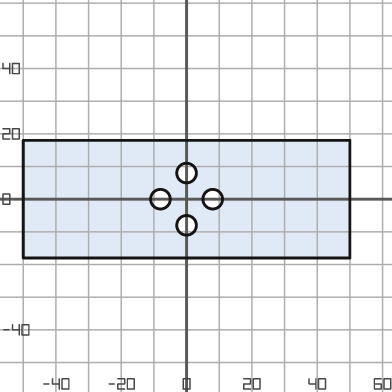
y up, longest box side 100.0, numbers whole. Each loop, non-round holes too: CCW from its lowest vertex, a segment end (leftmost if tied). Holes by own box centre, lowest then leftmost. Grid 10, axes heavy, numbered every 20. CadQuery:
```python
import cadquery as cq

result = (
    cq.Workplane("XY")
    .moveTo(-50.0, -18.0)
    .lineTo(50.0, -18.0)
    .lineTo(50.0, 18.0)
    .lineTo(-50.0, 18.0)
    .close()
    .moveTo(0.0, -8.0)
    .circle(3.0)
    .moveTo(-8.0, 0.0)
    .circle(3.0)
    .moveTo(8.0, 0.0)
    .circle(3.0)
    .moveTo(0.0, 8.0)
    .circle(3.0)
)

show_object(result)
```